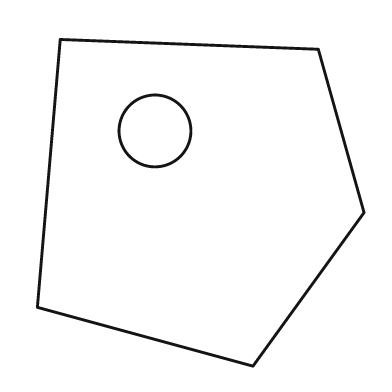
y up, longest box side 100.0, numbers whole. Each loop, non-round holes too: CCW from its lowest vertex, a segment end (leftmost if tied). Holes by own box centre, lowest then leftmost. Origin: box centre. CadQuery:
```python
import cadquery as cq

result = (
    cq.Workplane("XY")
    .moveTo(16.0, -50.0)
    .lineTo(50.0, -3.0)
    .lineTo(36.0, 47.0)
    .lineTo(-43.0, 50.0)
    .lineTo(-50.0, -32.0)
    .close()
    .moveTo(-14.0, 22.0)
    .circle(11.0)
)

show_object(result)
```